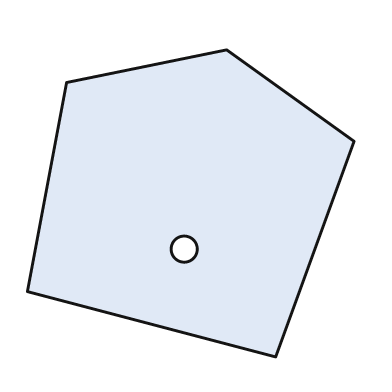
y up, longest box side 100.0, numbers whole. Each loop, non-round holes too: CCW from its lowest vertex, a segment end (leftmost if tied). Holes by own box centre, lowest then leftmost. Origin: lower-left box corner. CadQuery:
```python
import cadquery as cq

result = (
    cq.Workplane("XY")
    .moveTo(76.0, 0.0)
    .lineTo(100.0, 66.0)
    .lineTo(61.0, 94.0)
    .lineTo(12.0, 84.0)
    .lineTo(0.0, 20.0)
    .close()
    .moveTo(48.0, 33.0)
    .circle(4.0)
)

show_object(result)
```